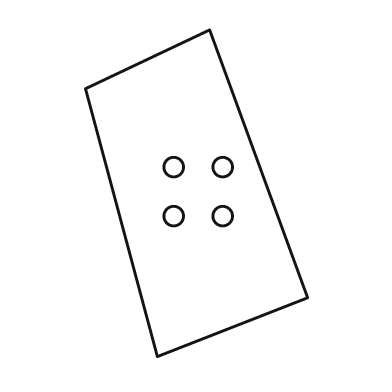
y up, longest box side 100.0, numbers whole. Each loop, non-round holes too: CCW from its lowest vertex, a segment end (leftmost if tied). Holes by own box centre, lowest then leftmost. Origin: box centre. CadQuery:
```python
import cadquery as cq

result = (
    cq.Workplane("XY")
    .moveTo(-12.0, -50.0)
    .lineTo(34.0, -32.0)
    .lineTo(4.0, 50.0)
    .lineTo(-34.0, 32.0)
    .close()
    .moveTo(-7.0, -7.0)
    .circle(3.0)
    .moveTo(8.0, -7.0)
    .circle(3.0)
    .moveTo(-7.0, 8.0)
    .circle(3.0)
    .moveTo(8.0, 8.0)
    .circle(3.0)
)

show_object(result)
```